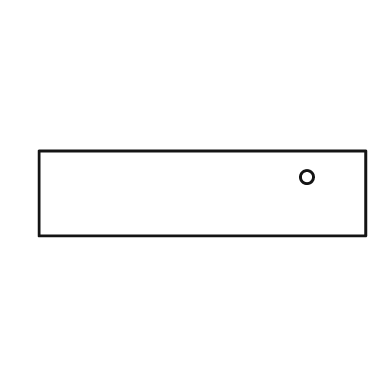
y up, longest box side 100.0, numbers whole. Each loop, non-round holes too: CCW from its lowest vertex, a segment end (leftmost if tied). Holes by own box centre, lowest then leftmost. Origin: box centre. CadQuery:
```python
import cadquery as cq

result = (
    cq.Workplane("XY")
    .moveTo(-50.0, -13.0)
    .lineTo(50.0, -13.0)
    .lineTo(50.0, 13.0)
    .lineTo(-50.0, 13.0)
    .close()
    .moveTo(32.0, 5.0)
    .circle(2.0)
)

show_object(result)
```